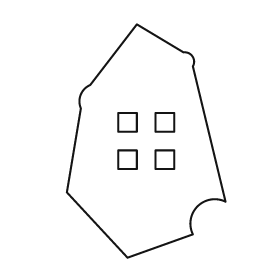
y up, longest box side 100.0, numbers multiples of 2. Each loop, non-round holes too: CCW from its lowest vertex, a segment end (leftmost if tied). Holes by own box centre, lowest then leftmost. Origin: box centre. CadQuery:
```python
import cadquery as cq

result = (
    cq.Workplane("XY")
    .moveTo(-8.0, -50.0)
    .lineTo(20.0, -40.0)
    .threePointArc((22.0, -28.0), (34.0, -26.0))
    .lineTo(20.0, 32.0)
    .threePointArc((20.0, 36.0), (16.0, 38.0))
    .lineTo(-4.0, 50.0)
    .lineTo(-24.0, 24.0)
    .threePointArc((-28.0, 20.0), (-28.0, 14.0))
    .lineTo(-34.0, -22.0)
    .close()
    .moveTo(-12.0, -12.0)
    .lineTo(-4.0, -12.0)
    .lineTo(-4.0, -4.0)
    .lineTo(-12.0, -4.0)
    .close()
    .moveTo(4.0, -12.0)
    .lineTo(12.0, -12.0)
    .lineTo(12.0, -4.0)
    .lineTo(4.0, -4.0)
    .close()
    .moveTo(-12.0, 4.0)
    .lineTo(-4.0, 4.0)
    .lineTo(-4.0, 12.0)
    .lineTo(-12.0, 12.0)
    .close()
    .moveTo(4.0, 4.0)
    .lineTo(12.0, 4.0)
    .lineTo(12.0, 12.0)
    .lineTo(4.0, 12.0)
    .close()
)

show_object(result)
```